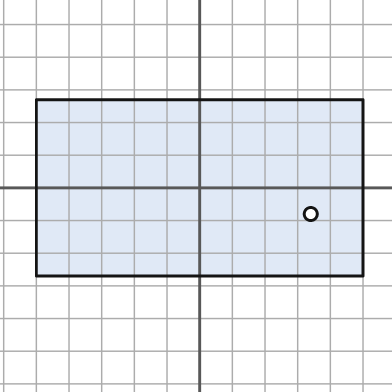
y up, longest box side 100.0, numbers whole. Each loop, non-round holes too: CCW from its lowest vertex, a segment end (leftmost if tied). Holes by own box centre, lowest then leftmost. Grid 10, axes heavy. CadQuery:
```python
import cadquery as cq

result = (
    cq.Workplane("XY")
    .moveTo(-50.0, -27.0)
    .lineTo(50.0, -27.0)
    .lineTo(50.0, 27.0)
    .lineTo(-50.0, 27.0)
    .close()
    .moveTo(34.0, -8.0)
    .circle(2.0)
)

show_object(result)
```